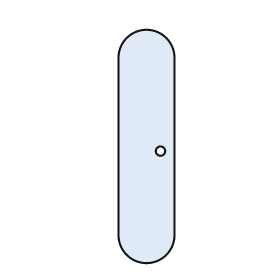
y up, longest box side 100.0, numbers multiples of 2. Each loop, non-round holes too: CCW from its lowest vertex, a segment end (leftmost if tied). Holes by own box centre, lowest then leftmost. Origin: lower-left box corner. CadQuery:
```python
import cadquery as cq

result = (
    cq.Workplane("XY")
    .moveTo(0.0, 12.0)
    .threePointArc((12.0, 0.0), (24.0, 12.0))
    .lineTo(24.0, 88.0)
    .threePointArc((12.0, 100.0), (0.0, 88.0))
    .close()
    .moveTo(18.0, 48.0)
    .circle(2.0)
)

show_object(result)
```